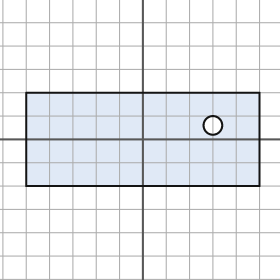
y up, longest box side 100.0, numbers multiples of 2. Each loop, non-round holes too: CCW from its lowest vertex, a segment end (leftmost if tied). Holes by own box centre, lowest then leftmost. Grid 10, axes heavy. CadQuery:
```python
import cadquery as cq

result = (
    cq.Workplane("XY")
    .moveTo(-50.0, -20.0)
    .lineTo(50.0, -20.0)
    .lineTo(50.0, 20.0)
    .lineTo(-50.0, 20.0)
    .close()
    .moveTo(30.0, 6.0)
    .circle(4.0)
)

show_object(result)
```